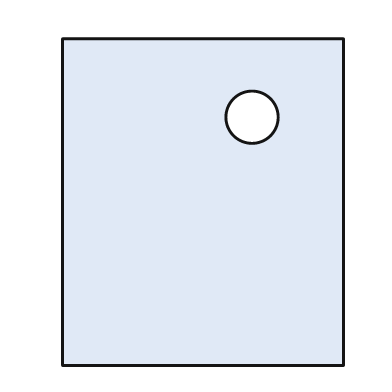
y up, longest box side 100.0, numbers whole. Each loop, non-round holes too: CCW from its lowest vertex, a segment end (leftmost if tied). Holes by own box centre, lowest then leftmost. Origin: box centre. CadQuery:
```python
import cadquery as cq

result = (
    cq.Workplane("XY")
    .moveTo(-43.0, -50.0)
    .lineTo(43.0, -50.0)
    .lineTo(43.0, 50.0)
    .lineTo(-43.0, 50.0)
    .close()
    .moveTo(15.0, 26.0)
    .circle(8.0)
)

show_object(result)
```